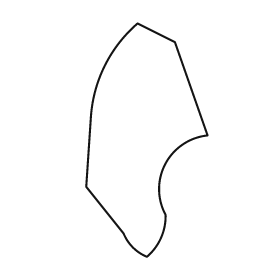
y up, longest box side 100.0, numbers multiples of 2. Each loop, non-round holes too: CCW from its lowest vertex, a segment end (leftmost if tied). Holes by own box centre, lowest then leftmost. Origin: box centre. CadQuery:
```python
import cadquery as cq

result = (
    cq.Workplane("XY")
    .moveTo(0.0, -50.0)
    .threePointArc((6.0, -42.0), (8.0, -32.0))
    .threePointArc((8.0, -10.0), (26.0, 2.0))
    .lineTo(12.0, 42.0)
    .lineTo(-4.0, 50.0)
    .threePointArc((-18.0, 32.0), (-24.0, 10.0))
    .lineTo(-26.0, -20.0)
    .lineTo(-10.0, -40.0)
    .threePointArc((-6.0, -46.0), (0.0, -50.0))
    .close()
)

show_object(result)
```